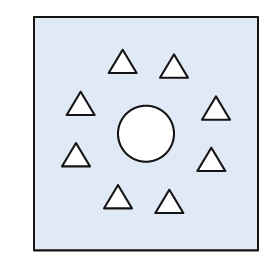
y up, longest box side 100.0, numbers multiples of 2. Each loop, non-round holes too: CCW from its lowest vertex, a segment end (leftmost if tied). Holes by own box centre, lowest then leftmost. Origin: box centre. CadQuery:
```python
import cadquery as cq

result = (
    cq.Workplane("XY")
    .moveTo(-48.0, -50.0)
    .lineTo(48.0, -50.0)
    .lineTo(48.0, 50.0)
    .lineTo(-48.0, 50.0)
    .close()
    .moveTo(4.0, -34.0)
    .lineTo(16.0, -34.0)
    .lineTo(10.0, -24.0)
    .close()
    .moveTo(-18.0, -32.0)
    .lineTo(-6.0, -32.0)
    .lineTo(-12.0, -22.0)
    .close()
    .moveTo(22.0, -16.0)
    .lineTo(34.0, -16.0)
    .lineTo(28.0, -6.0)
    .close()
    .moveTo(-36.0, -14.0)
    .lineTo(-24.0, -14.0)
    .lineTo(-30.0, -4.0)
    .close()
    .moveTo(0.0, 0.0)
    .circle(12.0)
    .moveTo(24.0, 6.0)
    .lineTo(36.0, 6.0)
    .lineTo(30.0, 16.0)
    .close()
    .moveTo(-34.0, 8.0)
    .lineTo(-22.0, 8.0)
    .lineTo(-28.0, 18.0)
    .close()
    .moveTo(6.0, 24.0)
    .lineTo(18.0, 24.0)
    .lineTo(12.0, 34.0)
    .close()
    .moveTo(-16.0, 26.0)
    .lineTo(-4.0, 26.0)
    .lineTo(-10.0, 36.0)
    .close()
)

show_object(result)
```